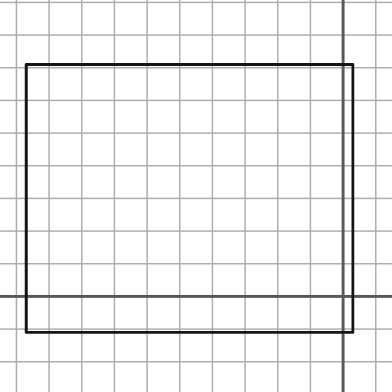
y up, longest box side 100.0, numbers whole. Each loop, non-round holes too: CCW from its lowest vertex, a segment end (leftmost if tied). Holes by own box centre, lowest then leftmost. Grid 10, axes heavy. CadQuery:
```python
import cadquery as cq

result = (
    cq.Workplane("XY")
    .moveTo(-97.0, -11.0)
    .lineTo(3.0, -11.0)
    .lineTo(3.0, 71.0)
    .lineTo(-97.0, 71.0)
    .close()
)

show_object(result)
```